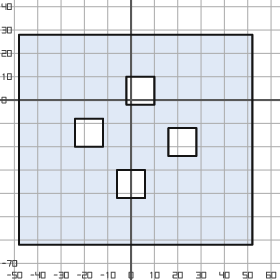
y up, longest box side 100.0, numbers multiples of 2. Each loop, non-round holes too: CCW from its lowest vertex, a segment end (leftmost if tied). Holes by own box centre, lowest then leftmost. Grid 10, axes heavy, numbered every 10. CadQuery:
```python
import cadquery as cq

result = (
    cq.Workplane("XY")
    .moveTo(-48.0, -62.0)
    .lineTo(52.0, -62.0)
    .lineTo(52.0, 28.0)
    .lineTo(-48.0, 28.0)
    .close()
    .moveTo(-6.0, -42.0)
    .lineTo(6.0, -42.0)
    .lineTo(6.0, -30.0)
    .lineTo(-6.0, -30.0)
    .close()
    .moveTo(16.0, -24.0)
    .lineTo(28.0, -24.0)
    .lineTo(28.0, -12.0)
    .lineTo(16.0, -12.0)
    .close()
    .moveTo(-24.0, -20.0)
    .lineTo(-12.0, -20.0)
    .lineTo(-12.0, -8.0)
    .lineTo(-24.0, -8.0)
    .close()
    .moveTo(-2.0, -2.0)
    .lineTo(10.0, -2.0)
    .lineTo(10.0, 10.0)
    .lineTo(-2.0, 10.0)
    .close()
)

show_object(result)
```